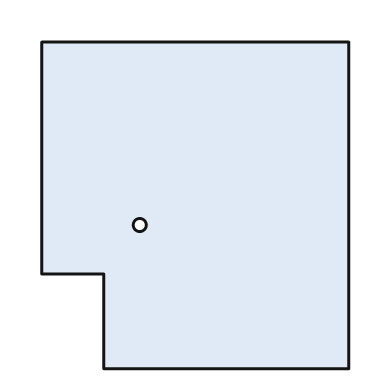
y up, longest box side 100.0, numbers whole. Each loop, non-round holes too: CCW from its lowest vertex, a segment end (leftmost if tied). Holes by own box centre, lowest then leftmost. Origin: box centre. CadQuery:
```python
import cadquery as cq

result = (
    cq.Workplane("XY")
    .moveTo(-28.0, -50.0)
    .lineTo(47.0, -50.0)
    .lineTo(47.0, 50.0)
    .lineTo(-47.0, 50.0)
    .lineTo(-47.0, -21.0)
    .lineTo(-28.0, -21.0)
    .close()
    .moveTo(-17.0, -6.0)
    .circle(2.0)
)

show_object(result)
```